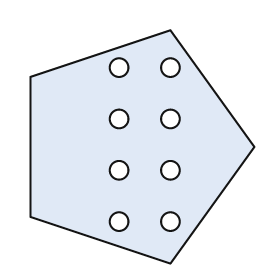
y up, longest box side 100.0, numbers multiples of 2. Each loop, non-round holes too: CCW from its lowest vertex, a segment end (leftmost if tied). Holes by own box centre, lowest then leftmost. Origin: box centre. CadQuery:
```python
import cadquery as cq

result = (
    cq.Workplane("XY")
    .moveTo(12.0, -50.0)
    .lineTo(48.0, 0.0)
    .lineTo(12.0, 50.0)
    .lineTo(-48.0, 30.0)
    .lineTo(-48.0, -30.0)
    .close()
    .moveTo(-10.0, -32.0)
    .circle(4.0)
    .moveTo(12.0, -32.0)
    .circle(4.0)
    .moveTo(-10.0, -10.0)
    .circle(4.0)
    .moveTo(12.0, -10.0)
    .circle(4.0)
    .moveTo(-10.0, 12.0)
    .circle(4.0)
    .moveTo(12.0, 12.0)
    .circle(4.0)
    .moveTo(-10.0, 34.0)
    .circle(4.0)
    .moveTo(12.0, 34.0)
    .circle(4.0)
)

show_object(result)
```